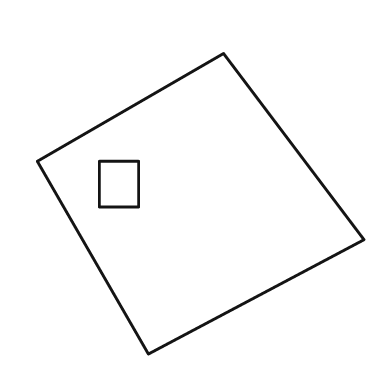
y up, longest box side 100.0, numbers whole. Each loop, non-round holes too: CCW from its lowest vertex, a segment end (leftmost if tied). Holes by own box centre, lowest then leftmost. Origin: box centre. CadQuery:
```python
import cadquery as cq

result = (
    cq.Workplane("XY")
    .moveTo(-16.0, -46.0)
    .lineTo(50.0, -11.0)
    .lineTo(7.0, 46.0)
    .lineTo(-50.0, 13.0)
    .close()
    .moveTo(-31.0, -1.0)
    .lineTo(-19.0, -1.0)
    .lineTo(-19.0, 13.0)
    .lineTo(-31.0, 13.0)
    .close()
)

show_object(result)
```